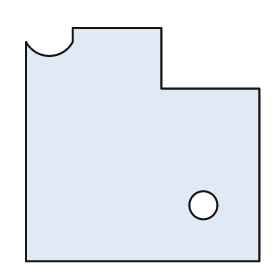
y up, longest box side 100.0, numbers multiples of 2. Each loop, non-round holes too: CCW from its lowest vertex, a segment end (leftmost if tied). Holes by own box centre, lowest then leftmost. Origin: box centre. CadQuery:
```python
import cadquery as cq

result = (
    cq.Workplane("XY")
    .moveTo(-50.0, -50.0)
    .lineTo(50.0, -50.0)
    .lineTo(50.0, 24.0)
    .lineTo(8.0, 24.0)
    .lineTo(8.0, 50.0)
    .lineTo(-30.0, 50.0)
    .lineTo(-30.0, 44.0)
    .threePointArc((-40.0, 38.0), (-50.0, 44.0))
    .close()
    .moveTo(26.0, -26.0)
    .circle(6.0)
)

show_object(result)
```